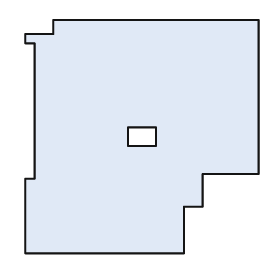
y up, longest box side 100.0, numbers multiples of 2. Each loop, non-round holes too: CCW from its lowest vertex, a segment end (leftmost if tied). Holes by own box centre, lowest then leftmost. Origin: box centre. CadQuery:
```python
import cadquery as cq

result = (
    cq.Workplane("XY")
    .moveTo(-50.0, -50.0)
    .lineTo(18.0, -50.0)
    .lineTo(18.0, -30.0)
    .lineTo(26.0, -30.0)
    .lineTo(26.0, -16.0)
    .lineTo(50.0, -16.0)
    .lineTo(50.0, 50.0)
    .lineTo(-38.0, 50.0)
    .lineTo(-38.0, 44.0)
    .lineTo(-50.0, 44.0)
    .lineTo(-50.0, 40.0)
    .lineTo(-46.0, 40.0)
    .lineTo(-46.0, -18.0)
    .lineTo(-50.0, -18.0)
    .close()
    .moveTo(-6.0, -4.0)
    .lineTo(6.0, -4.0)
    .lineTo(6.0, 4.0)
    .lineTo(-6.0, 4.0)
    .close()
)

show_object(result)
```